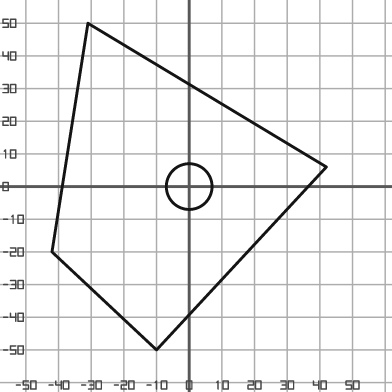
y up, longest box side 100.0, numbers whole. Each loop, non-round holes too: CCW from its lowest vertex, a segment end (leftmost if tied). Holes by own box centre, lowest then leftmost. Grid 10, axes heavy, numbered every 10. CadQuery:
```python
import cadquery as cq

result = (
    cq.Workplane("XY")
    .moveTo(-10.0, -50.0)
    .lineTo(42.0, 6.0)
    .lineTo(-31.0, 50.0)
    .lineTo(-42.0, -20.0)
    .close()
    .moveTo(0.0, 0.0)
    .circle(7.0)
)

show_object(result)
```